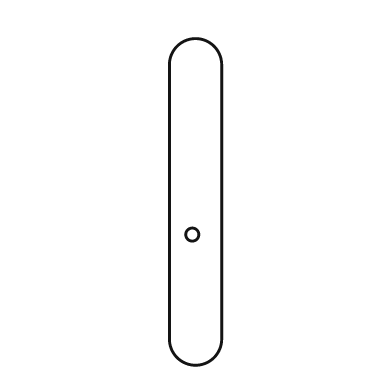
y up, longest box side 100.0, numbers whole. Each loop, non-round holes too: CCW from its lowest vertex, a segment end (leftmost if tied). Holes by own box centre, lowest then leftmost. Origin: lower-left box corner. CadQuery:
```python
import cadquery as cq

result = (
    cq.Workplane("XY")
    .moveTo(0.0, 8.0)
    .threePointArc((8.0, 0.0), (16.0, 8.0))
    .lineTo(16.0, 92.0)
    .threePointArc((8.0, 100.0), (0.0, 92.0))
    .close()
    .moveTo(7.0, 40.0)
    .circle(2.0)
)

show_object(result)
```